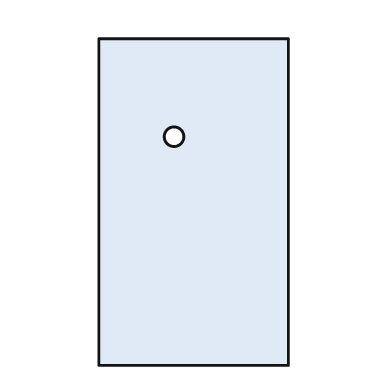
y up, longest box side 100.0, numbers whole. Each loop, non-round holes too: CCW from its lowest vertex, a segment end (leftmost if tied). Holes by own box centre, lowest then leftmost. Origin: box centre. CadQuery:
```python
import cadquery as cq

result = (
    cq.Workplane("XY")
    .moveTo(-29.0, -50.0)
    .lineTo(29.0, -50.0)
    .lineTo(29.0, 50.0)
    .lineTo(-29.0, 50.0)
    .close()
    .moveTo(-6.0, 20.0)
    .circle(3.0)
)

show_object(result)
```